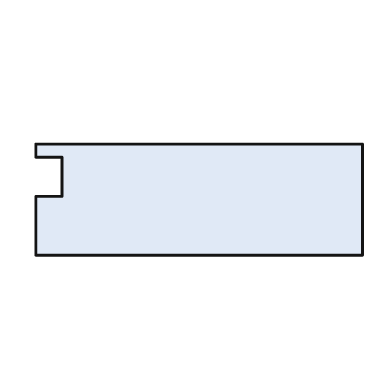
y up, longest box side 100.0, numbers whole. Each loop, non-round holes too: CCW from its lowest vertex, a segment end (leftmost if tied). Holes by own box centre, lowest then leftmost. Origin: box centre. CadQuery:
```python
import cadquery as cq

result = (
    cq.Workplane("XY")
    .moveTo(-50.0, -17.0)
    .lineTo(50.0, -17.0)
    .lineTo(50.0, 17.0)
    .lineTo(-50.0, 17.0)
    .lineTo(-50.0, 13.0)
    .lineTo(-42.0, 13.0)
    .lineTo(-42.0, 1.0)
    .lineTo(-50.0, 1.0)
    .close()
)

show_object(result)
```